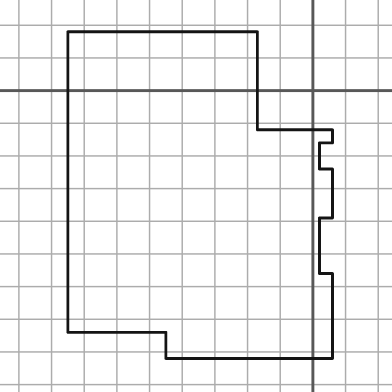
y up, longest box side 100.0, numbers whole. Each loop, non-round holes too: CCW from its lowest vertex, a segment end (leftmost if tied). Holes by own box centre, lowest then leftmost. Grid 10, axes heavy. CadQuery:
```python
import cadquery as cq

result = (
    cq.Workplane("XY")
    .moveTo(-45.0, -82.0)
    .lineTo(6.0, -82.0)
    .lineTo(6.0, -56.0)
    .lineTo(2.0, -56.0)
    .lineTo(2.0, -39.0)
    .lineTo(6.0, -39.0)
    .lineTo(6.0, -24.0)
    .lineTo(2.0, -24.0)
    .lineTo(2.0, -16.0)
    .lineTo(6.0, -16.0)
    .lineTo(6.0, -12.0)
    .lineTo(-17.0, -12.0)
    .lineTo(-17.0, 18.0)
    .lineTo(-75.0, 18.0)
    .lineTo(-75.0, -74.0)
    .lineTo(-45.0, -74.0)
    .close()
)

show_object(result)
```